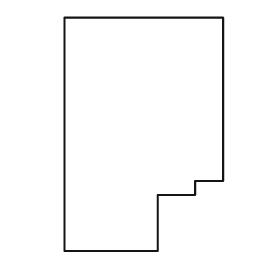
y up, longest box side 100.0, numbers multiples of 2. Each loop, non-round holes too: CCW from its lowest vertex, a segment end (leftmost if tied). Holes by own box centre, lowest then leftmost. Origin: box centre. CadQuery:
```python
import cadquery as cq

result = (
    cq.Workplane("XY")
    .moveTo(-34.0, -50.0)
    .lineTo(6.0, -50.0)
    .lineTo(6.0, -26.0)
    .lineTo(22.0, -26.0)
    .lineTo(22.0, -20.0)
    .lineTo(34.0, -20.0)
    .lineTo(34.0, 50.0)
    .lineTo(-34.0, 50.0)
    .close()
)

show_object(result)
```